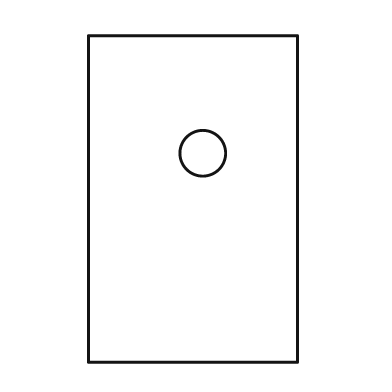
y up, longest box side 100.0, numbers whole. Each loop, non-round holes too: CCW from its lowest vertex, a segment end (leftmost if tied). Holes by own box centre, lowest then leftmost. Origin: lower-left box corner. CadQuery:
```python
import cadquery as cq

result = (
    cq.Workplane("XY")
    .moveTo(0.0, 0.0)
    .lineTo(64.0, 0.0)
    .lineTo(64.0, 100.0)
    .lineTo(0.0, 100.0)
    .close()
    .moveTo(35.0, 64.0)
    .circle(7.0)
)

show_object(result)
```